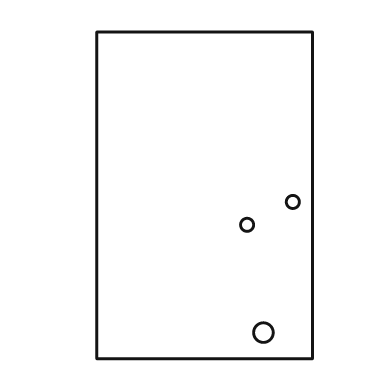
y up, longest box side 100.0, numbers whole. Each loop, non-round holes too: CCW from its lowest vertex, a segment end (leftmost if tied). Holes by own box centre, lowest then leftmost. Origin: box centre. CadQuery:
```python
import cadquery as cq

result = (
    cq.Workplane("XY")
    .moveTo(-33.0, -50.0)
    .lineTo(33.0, -50.0)
    .lineTo(33.0, 50.0)
    .lineTo(-33.0, 50.0)
    .close()
    .moveTo(18.0, -42.0)
    .circle(3.0)
    .moveTo(13.0, -9.0)
    .circle(2.0)
    .moveTo(27.0, -2.0)
    .circle(2.0)
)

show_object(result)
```